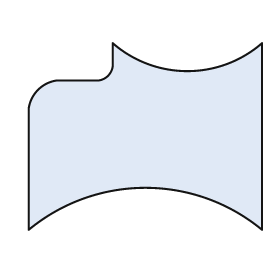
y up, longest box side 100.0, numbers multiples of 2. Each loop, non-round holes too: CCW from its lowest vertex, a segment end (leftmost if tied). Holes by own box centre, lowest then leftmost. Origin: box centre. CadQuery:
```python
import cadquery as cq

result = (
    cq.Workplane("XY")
    .moveTo(-50.0, -40.0)
    .threePointArc((0.0, -22.0), (50.0, -40.0))
    .lineTo(50.0, 40.0)
    .threePointArc((18.0, 28.0), (-14.0, 40.0))
    .lineTo(-14.0, 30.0)
    .threePointArc((-16.0, 26.0), (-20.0, 24.0))
    .lineTo(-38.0, 24.0)
    .threePointArc((-46.0, 20.0), (-50.0, 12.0))
    .close()
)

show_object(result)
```